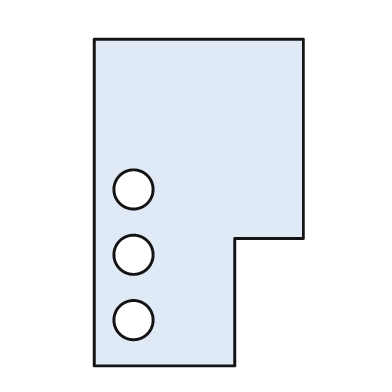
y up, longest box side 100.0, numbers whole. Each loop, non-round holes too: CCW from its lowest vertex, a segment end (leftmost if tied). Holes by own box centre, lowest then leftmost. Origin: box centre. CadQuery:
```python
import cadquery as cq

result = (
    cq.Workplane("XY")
    .moveTo(-32.0, -50.0)
    .lineTo(11.0, -50.0)
    .lineTo(11.0, -11.0)
    .lineTo(32.0, -11.0)
    .lineTo(32.0, 50.0)
    .lineTo(-32.0, 50.0)
    .close()
    .moveTo(-20.0, -36.0)
    .circle(6.0)
    .moveTo(-20.0, -16.0)
    .circle(6.0)
    .moveTo(-20.0, 4.0)
    .circle(6.0)
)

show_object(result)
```